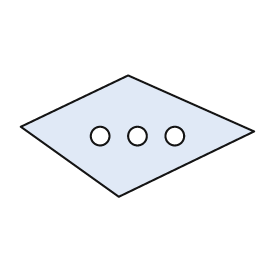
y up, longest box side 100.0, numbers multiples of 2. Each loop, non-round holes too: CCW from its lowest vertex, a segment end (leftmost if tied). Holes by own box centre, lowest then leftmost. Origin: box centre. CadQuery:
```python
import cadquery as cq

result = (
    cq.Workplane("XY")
    .moveTo(-8.0, -26.0)
    .lineTo(50.0, 2.0)
    .lineTo(-4.0, 26.0)
    .lineTo(-50.0, 4.0)
    .close()
    .moveTo(-16.0, 0.0)
    .circle(4.0)
    .moveTo(0.0, 0.0)
    .circle(4.0)
    .moveTo(16.0, 0.0)
    .circle(4.0)
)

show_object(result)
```